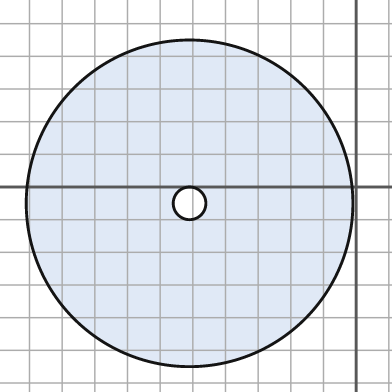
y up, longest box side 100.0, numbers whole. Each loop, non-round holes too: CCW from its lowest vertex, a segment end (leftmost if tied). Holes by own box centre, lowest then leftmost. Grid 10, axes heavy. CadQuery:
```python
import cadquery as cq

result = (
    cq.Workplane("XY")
    .moveTo(-51.0, -5.0)
    .circle(50.0)
    .moveTo(-51.0, -5.0)
    .circle(5.0)
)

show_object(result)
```